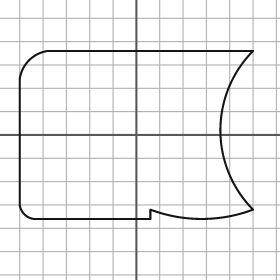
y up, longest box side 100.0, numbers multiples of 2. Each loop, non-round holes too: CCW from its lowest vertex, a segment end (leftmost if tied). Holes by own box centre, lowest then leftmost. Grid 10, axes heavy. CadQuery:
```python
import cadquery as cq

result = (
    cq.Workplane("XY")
    .moveTo(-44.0, -36.0)
    .lineTo(6.0, -36.0)
    .lineTo(6.0, -32.0)
    .threePointArc((28.0, -36.0), (50.0, -32.0))
    .threePointArc((36.0, 2.0), (50.0, 36.0))
    .lineTo(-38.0, 36.0)
    .threePointArc((-46.0, 32.0), (-50.0, 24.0))
    .lineTo(-50.0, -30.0)
    .threePointArc((-48.0, -34.0), (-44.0, -36.0))
    .close()
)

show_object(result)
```